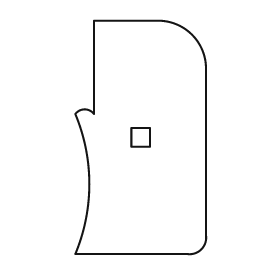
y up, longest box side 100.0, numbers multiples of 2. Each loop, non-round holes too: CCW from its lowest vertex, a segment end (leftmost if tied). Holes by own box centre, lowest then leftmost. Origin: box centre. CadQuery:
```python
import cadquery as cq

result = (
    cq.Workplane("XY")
    .moveTo(-28.0, -50.0)
    .lineTo(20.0, -50.0)
    .threePointArc((26.0, -48.0), (28.0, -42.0))
    .lineTo(28.0, 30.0)
    .threePointArc((22.0, 44.0), (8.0, 50.0))
    .lineTo(-20.0, 50.0)
    .lineTo(-20.0, 10.0)
    .threePointArc((-24.0, 12.0), (-28.0, 10.0))
    .threePointArc((-22.0, -20.0), (-28.0, -50.0))
    .close()
    .moveTo(-4.0, -4.0)
    .lineTo(4.0, -4.0)
    .lineTo(4.0, 4.0)
    .lineTo(-4.0, 4.0)
    .close()
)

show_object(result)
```